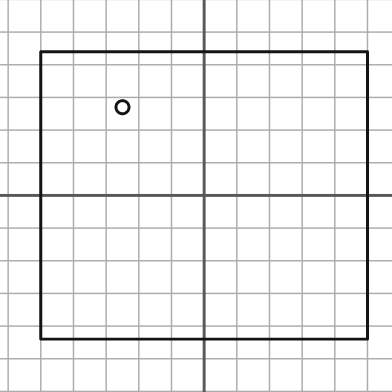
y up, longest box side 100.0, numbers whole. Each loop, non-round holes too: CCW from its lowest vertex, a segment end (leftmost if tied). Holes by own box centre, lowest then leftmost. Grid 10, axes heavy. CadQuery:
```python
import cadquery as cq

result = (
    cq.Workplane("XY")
    .moveTo(-50.0, -44.0)
    .lineTo(50.0, -44.0)
    .lineTo(50.0, 44.0)
    .lineTo(-50.0, 44.0)
    .close()
    .moveTo(-25.0, 27.0)
    .circle(2.0)
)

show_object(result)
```